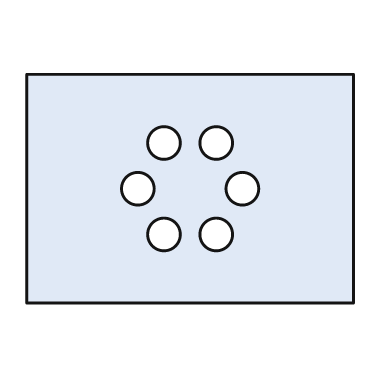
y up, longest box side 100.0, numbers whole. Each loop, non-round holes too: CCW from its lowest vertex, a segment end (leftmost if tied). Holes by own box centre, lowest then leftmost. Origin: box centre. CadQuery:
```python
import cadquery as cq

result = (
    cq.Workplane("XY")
    .moveTo(-50.0, -35.0)
    .lineTo(50.0, -35.0)
    .lineTo(50.0, 35.0)
    .lineTo(-50.0, 35.0)
    .close()
    .moveTo(-8.0, -14.0)
    .circle(5.0)
    .moveTo(8.0, -14.0)
    .circle(5.0)
    .moveTo(-16.0, 0.0)
    .circle(5.0)
    .moveTo(16.0, 0.0)
    .circle(5.0)
    .moveTo(-8.0, 14.0)
    .circle(5.0)
    .moveTo(8.0, 14.0)
    .circle(5.0)
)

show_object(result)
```